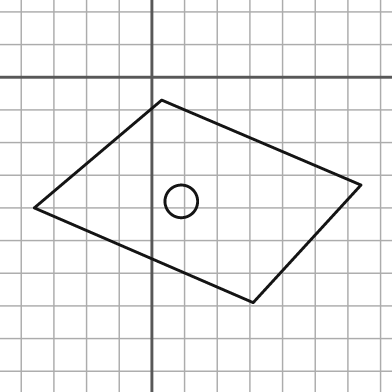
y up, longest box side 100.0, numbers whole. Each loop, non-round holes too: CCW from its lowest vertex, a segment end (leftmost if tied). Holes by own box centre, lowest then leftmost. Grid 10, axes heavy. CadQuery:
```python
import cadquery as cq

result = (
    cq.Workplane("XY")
    .moveTo(31.0, -69.0)
    .lineTo(64.0, -33.0)
    .lineTo(3.0, -7.0)
    .lineTo(-36.0, -40.0)
    .close()
    .moveTo(9.0, -38.0)
    .circle(5.0)
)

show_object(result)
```